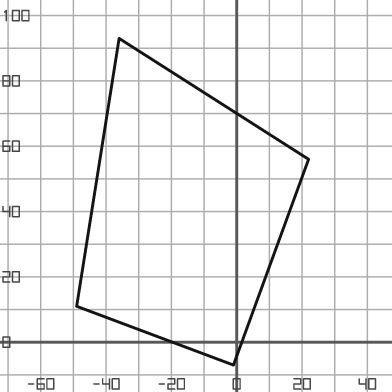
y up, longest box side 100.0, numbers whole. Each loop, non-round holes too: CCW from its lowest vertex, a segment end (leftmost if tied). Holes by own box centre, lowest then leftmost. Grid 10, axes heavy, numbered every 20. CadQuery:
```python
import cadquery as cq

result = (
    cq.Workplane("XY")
    .moveTo(-1.0, -7.0)
    .lineTo(22.0, 56.0)
    .lineTo(-36.0, 93.0)
    .lineTo(-49.0, 11.0)
    .close()
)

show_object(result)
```